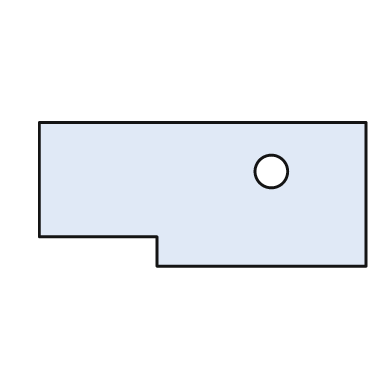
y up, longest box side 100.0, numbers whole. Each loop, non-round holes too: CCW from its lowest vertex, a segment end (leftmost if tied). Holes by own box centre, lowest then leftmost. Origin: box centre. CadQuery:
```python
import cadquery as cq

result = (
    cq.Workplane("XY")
    .moveTo(-14.0, -22.0)
    .lineTo(50.0, -22.0)
    .lineTo(50.0, 22.0)
    .lineTo(-50.0, 22.0)
    .lineTo(-50.0, -13.0)
    .lineTo(-14.0, -13.0)
    .close()
    .moveTo(21.0, 7.0)
    .circle(5.0)
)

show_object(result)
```